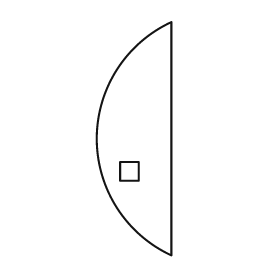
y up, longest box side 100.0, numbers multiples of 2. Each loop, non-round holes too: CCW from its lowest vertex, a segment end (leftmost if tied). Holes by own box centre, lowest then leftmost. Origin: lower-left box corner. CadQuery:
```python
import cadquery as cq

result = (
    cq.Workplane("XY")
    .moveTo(32.0, 0.0)
    .lineTo(32.0, 100.0)
    .threePointArc((0.0, 50.0), (32.0, 0.0))
    .close()
    .moveTo(10.0, 32.0)
    .lineTo(18.0, 32.0)
    .lineTo(18.0, 40.0)
    .lineTo(10.0, 40.0)
    .close()
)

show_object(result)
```